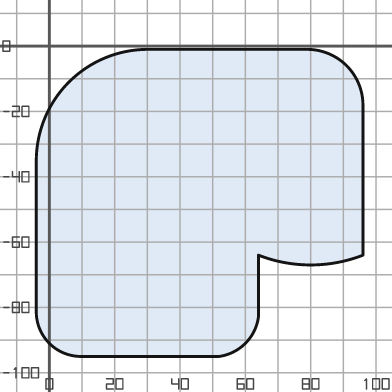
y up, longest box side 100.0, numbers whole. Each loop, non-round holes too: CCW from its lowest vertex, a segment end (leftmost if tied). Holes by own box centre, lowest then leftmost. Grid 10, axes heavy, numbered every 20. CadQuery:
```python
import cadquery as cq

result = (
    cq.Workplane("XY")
    .moveTo(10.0, -95.0)
    .lineTo(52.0, -95.0)
    .threePointArc((60.0, -91.0), (64.0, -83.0))
    .lineTo(64.0, -64.0)
    .threePointArc((80.0, -67.0), (96.0, -64.0))
    .lineTo(96.0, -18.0)
    .threePointArc((91.0, -6.0), (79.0, -1.0))
    .lineTo(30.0, -1.0)
    .threePointArc((6.0, -11.0), (-4.0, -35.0))
    .lineTo(-4.0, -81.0)
    .threePointArc((0.0, -91.0), (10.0, -95.0))
    .close()
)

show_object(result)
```